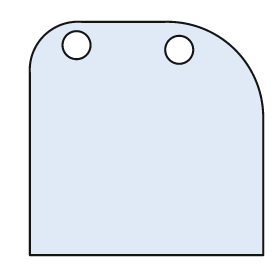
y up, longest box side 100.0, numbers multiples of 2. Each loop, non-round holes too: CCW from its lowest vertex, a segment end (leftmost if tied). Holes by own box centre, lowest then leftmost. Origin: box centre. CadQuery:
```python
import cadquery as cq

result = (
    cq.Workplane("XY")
    .moveTo(-50.0, -50.0)
    .lineTo(50.0, -50.0)
    .lineTo(50.0, 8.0)
    .threePointArc((38.0, 38.0), (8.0, 50.0))
    .lineTo(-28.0, 50.0)
    .threePointArc((-44.0, 44.0), (-50.0, 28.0))
    .close()
    .moveTo(14.0, 38.0)
    .circle(6.0)
    .moveTo(-30.0, 40.0)
    .circle(6.0)
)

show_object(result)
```